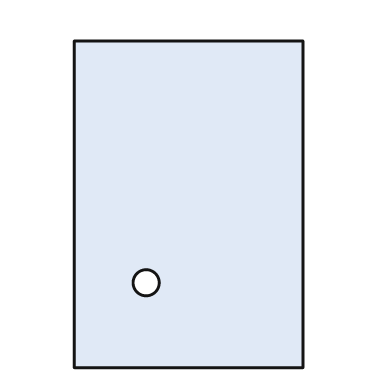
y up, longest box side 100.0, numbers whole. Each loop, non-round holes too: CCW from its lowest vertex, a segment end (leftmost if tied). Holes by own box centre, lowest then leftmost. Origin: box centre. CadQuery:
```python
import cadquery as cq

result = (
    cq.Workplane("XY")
    .moveTo(-35.0, -50.0)
    .lineTo(35.0, -50.0)
    .lineTo(35.0, 50.0)
    .lineTo(-35.0, 50.0)
    .close()
    .moveTo(-13.0, -24.0)
    .circle(4.0)
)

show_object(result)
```